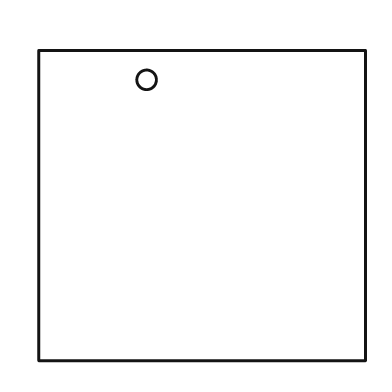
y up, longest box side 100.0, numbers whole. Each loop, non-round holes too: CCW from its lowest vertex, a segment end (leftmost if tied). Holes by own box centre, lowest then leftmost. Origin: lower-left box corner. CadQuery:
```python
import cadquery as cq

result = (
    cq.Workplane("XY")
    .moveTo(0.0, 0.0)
    .lineTo(100.0, 0.0)
    .lineTo(100.0, 95.0)
    .lineTo(0.0, 95.0)
    .close()
    .moveTo(33.0, 86.0)
    .circle(3.0)
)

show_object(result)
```